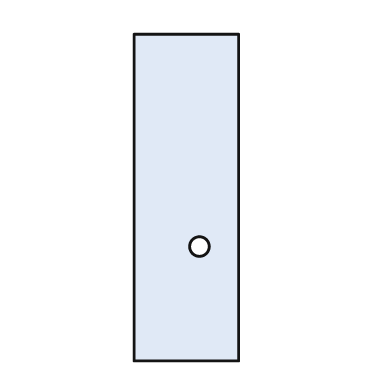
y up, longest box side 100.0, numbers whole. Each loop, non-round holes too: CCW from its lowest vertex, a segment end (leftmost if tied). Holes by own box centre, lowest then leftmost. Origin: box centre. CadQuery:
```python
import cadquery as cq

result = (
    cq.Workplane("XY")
    .moveTo(-16.0, -50.0)
    .lineTo(16.0, -50.0)
    .lineTo(16.0, 50.0)
    .lineTo(-16.0, 50.0)
    .close()
    .moveTo(4.0, -15.0)
    .circle(3.0)
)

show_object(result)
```